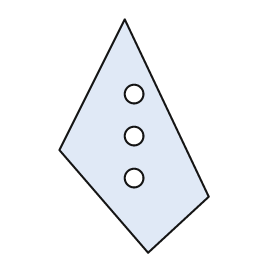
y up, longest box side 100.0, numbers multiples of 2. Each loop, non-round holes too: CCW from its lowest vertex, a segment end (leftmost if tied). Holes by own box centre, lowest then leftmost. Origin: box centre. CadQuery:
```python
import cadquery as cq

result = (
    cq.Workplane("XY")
    .moveTo(6.0, -50.0)
    .lineTo(32.0, -26.0)
    .lineTo(-4.0, 50.0)
    .lineTo(-32.0, -6.0)
    .close()
    .moveTo(0.0, -18.0)
    .circle(4.0)
    .moveTo(0.0, 0.0)
    .circle(4.0)
    .moveTo(0.0, 18.0)
    .circle(4.0)
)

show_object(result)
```